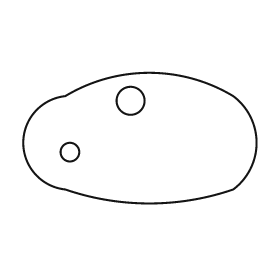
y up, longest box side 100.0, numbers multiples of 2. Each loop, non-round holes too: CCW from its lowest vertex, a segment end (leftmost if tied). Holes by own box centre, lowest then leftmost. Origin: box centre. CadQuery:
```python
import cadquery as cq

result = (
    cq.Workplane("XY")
    .moveTo(-32.0, -22.0)
    .threePointArc((4.0, -28.0), (40.0, -22.0))
    .threePointArc((50.0, -2.0), (40.0, 18.0))
    .threePointArc((4.0, 28.0), (-32.0, 18.0))
    .threePointArc((-50.0, -2.0), (-32.0, -22.0))
    .close()
    .moveTo(-30.0, -6.0)
    .circle(4.0)
    .moveTo(-4.0, 16.0)
    .circle(6.0)
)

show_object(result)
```